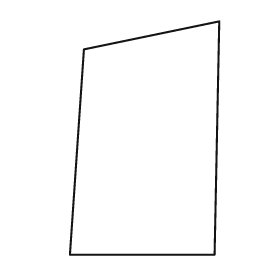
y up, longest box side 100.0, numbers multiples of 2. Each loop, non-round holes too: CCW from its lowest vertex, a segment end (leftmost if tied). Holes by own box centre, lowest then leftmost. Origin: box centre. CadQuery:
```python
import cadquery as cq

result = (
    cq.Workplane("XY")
    .moveTo(-32.0, -50.0)
    .lineTo(30.0, -50.0)
    .lineTo(32.0, 50.0)
    .lineTo(-26.0, 38.0)
    .close()
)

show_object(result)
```